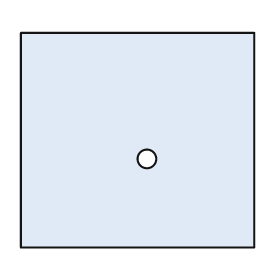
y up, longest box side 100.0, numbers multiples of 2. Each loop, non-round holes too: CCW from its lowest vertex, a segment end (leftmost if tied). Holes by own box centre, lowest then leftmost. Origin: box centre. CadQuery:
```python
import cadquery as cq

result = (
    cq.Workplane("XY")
    .moveTo(-50.0, -46.0)
    .lineTo(50.0, -46.0)
    .lineTo(50.0, 46.0)
    .lineTo(-50.0, 46.0)
    .close()
    .moveTo(4.0, -8.0)
    .circle(4.0)
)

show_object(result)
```